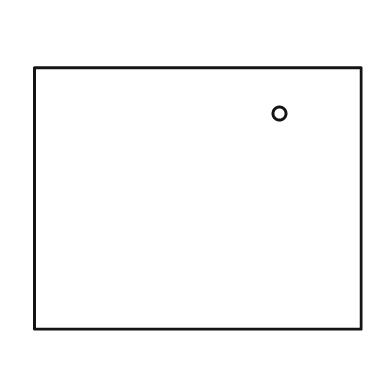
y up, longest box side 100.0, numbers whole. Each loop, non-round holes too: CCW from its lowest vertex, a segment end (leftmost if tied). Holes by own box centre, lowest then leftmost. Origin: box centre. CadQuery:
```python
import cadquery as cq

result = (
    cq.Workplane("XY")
    .moveTo(-50.0, -40.0)
    .lineTo(50.0, -40.0)
    .lineTo(50.0, 40.0)
    .lineTo(-50.0, 40.0)
    .close()
    .moveTo(25.0, 26.0)
    .circle(2.0)
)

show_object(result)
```